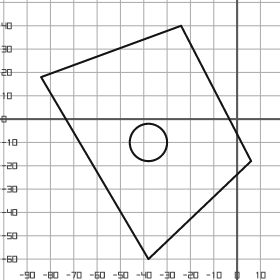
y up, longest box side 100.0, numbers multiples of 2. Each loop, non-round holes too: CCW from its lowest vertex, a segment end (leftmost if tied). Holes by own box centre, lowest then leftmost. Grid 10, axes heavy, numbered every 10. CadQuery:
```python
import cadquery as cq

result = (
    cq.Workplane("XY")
    .moveTo(-38.0, -60.0)
    .lineTo(6.0, -18.0)
    .lineTo(-24.0, 40.0)
    .lineTo(-84.0, 18.0)
    .close()
    .moveTo(-38.0, -10.0)
    .circle(8.0)
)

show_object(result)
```